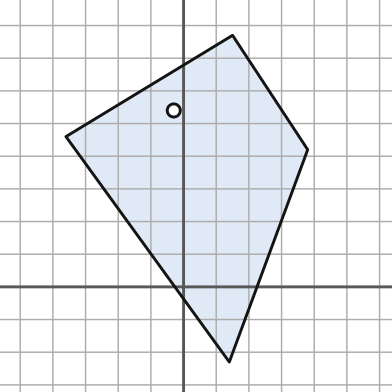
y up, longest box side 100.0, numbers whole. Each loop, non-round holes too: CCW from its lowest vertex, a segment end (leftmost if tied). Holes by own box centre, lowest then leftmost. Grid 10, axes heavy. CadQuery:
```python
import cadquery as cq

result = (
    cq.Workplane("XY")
    .moveTo(14.0, -23.0)
    .lineTo(38.0, 42.0)
    .lineTo(15.0, 77.0)
    .lineTo(-36.0, 46.0)
    .close()
    .moveTo(-3.0, 54.0)
    .circle(2.0)
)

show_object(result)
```